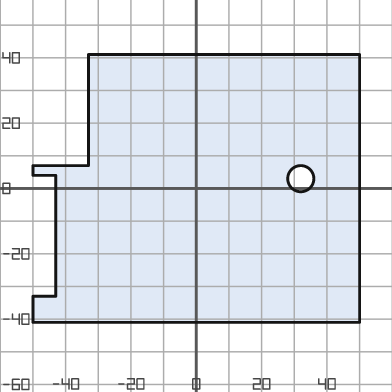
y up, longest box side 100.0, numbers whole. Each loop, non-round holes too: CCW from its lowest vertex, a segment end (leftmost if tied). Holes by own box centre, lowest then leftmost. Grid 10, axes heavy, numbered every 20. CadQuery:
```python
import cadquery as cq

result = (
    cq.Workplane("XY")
    .moveTo(-50.0, -41.0)
    .lineTo(50.0, -41.0)
    .lineTo(50.0, 41.0)
    .lineTo(-33.0, 41.0)
    .lineTo(-33.0, 7.0)
    .lineTo(-50.0, 7.0)
    .lineTo(-50.0, 4.0)
    .lineTo(-43.0, 4.0)
    .lineTo(-43.0, -33.0)
    .lineTo(-50.0, -33.0)
    .close()
    .moveTo(32.0, 3.0)
    .circle(4.0)
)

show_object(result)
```